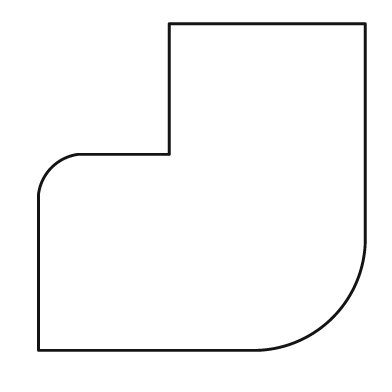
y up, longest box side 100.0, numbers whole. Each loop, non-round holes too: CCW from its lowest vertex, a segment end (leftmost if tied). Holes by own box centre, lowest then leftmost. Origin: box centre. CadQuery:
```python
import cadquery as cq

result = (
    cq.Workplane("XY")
    .moveTo(-50.0, -50.0)
    .lineTo(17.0, -50.0)
    .threePointArc((40.0, -40.0), (50.0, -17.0))
    .lineTo(50.0, 50.0)
    .lineTo(-10.0, 50.0)
    .lineTo(-10.0, 10.0)
    .lineTo(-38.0, 10.0)
    .threePointArc((-46.0, 6.0), (-50.0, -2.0))
    .close()
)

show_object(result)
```